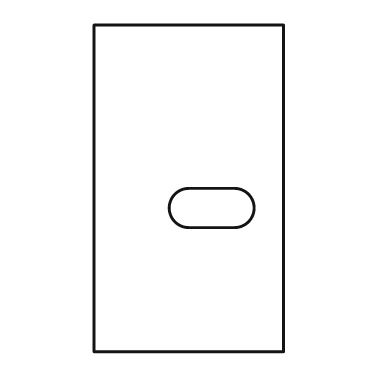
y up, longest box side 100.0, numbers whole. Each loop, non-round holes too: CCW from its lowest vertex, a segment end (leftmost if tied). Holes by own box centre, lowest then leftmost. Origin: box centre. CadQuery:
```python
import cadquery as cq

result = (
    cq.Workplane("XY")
    .moveTo(-29.0, -50.0)
    .lineTo(29.0, -50.0)
    .lineTo(29.0, 50.0)
    .lineTo(-29.0, 50.0)
    .close()
    .moveTo(0.0, -12.0)
    .lineTo(14.0, -12.0)
    .threePointArc((20.0, -6.0), (14.0, 0.0))
    .lineTo(0.0, 0.0)
    .threePointArc((-6.0, -6.0), (0.0, -12.0))
    .close()
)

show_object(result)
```